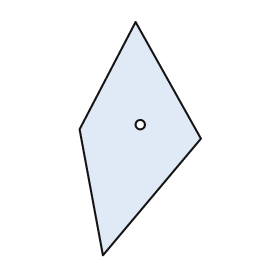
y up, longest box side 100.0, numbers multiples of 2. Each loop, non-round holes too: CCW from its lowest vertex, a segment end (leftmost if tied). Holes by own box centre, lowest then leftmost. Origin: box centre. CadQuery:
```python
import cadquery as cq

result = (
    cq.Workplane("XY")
    .moveTo(-16.0, -50.0)
    .lineTo(26.0, 0.0)
    .lineTo(-2.0, 50.0)
    .lineTo(-26.0, 4.0)
    .close()
    .moveTo(0.0, 6.0)
    .circle(2.0)
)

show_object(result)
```